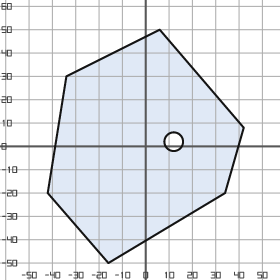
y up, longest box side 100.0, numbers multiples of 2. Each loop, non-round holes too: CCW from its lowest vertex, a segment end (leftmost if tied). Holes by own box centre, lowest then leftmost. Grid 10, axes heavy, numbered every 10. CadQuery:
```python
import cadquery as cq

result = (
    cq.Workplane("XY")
    .moveTo(-16.0, -50.0)
    .lineTo(34.0, -20.0)
    .lineTo(42.0, 8.0)
    .lineTo(6.0, 50.0)
    .lineTo(-34.0, 30.0)
    .lineTo(-42.0, -20.0)
    .close()
    .moveTo(12.0, 2.0)
    .circle(4.0)
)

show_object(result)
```